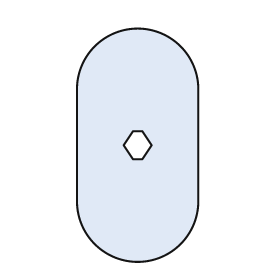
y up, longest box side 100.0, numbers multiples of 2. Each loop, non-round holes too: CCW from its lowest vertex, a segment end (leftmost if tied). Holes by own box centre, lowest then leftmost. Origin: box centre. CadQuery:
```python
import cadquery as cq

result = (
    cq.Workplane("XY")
    .moveTo(-26.0, -24.0)
    .threePointArc((0.0, -50.0), (26.0, -24.0))
    .lineTo(26.0, 24.0)
    .threePointArc((0.0, 50.0), (-26.0, 24.0))
    .close()
    .moveTo(-2.0, -6.0)
    .lineTo(2.0, -6.0)
    .lineTo(6.0, 0.0)
    .lineTo(2.0, 6.0)
    .lineTo(-2.0, 6.0)
    .lineTo(-6.0, 0.0)
    .close()
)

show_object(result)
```